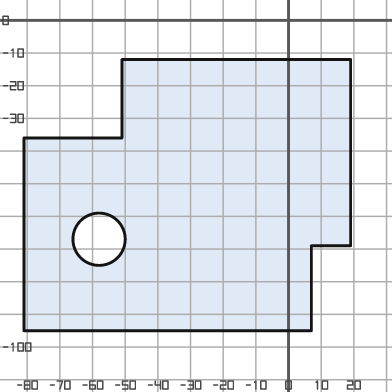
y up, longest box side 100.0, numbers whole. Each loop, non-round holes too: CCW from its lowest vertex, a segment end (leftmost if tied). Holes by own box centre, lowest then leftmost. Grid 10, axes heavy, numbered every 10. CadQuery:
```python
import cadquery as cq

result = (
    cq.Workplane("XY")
    .moveTo(-81.0, -95.0)
    .lineTo(7.0, -95.0)
    .lineTo(7.0, -69.0)
    .lineTo(19.0, -69.0)
    .lineTo(19.0, -12.0)
    .lineTo(-51.0, -12.0)
    .lineTo(-51.0, -36.0)
    .lineTo(-81.0, -36.0)
    .close()
    .moveTo(-58.0, -67.0)
    .circle(8.0)
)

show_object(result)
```